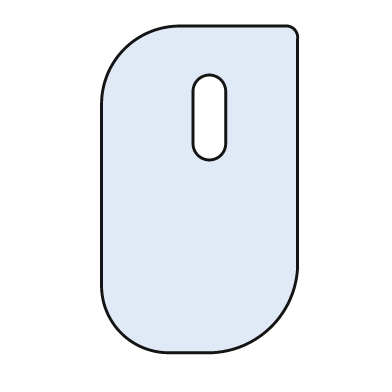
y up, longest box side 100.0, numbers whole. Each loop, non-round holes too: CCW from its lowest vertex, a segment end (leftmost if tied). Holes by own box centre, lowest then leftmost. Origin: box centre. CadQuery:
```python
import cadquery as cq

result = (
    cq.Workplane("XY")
    .moveTo(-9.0, -50.0)
    .lineTo(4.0, -50.0)
    .threePointArc((22.0, -42.0), (30.0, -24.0))
    .lineTo(30.0, 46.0)
    .threePointArc((29.0, 49.0), (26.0, 50.0))
    .lineTo(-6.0, 50.0)
    .threePointArc((-23.0, 43.0), (-30.0, 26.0))
    .lineTo(-30.0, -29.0)
    .threePointArc((-24.0, -44.0), (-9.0, -50.0))
    .close()
    .moveTo(-2.0, 14.0)
    .threePointArc((3.0, 9.0), (8.0, 14.0))
    .lineTo(8.0, 30.0)
    .threePointArc((3.0, 35.0), (-2.0, 30.0))
    .close()
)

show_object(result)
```